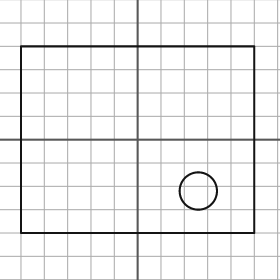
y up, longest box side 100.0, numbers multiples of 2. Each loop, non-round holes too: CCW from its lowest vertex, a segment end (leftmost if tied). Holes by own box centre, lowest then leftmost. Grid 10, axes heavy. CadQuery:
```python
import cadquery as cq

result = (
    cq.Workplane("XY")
    .moveTo(-50.0, -40.0)
    .lineTo(50.0, -40.0)
    .lineTo(50.0, 40.0)
    .lineTo(-50.0, 40.0)
    .close()
    .moveTo(26.0, -22.0)
    .circle(8.0)
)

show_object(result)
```